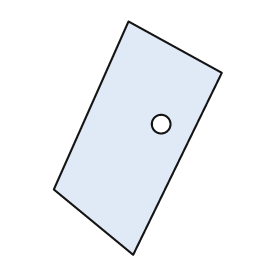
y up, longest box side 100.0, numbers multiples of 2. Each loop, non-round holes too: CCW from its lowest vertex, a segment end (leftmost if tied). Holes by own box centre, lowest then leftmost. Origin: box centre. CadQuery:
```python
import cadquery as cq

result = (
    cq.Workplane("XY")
    .moveTo(-2.0, -50.0)
    .lineTo(36.0, 28.0)
    .lineTo(-4.0, 50.0)
    .lineTo(-36.0, -22.0)
    .close()
    .moveTo(10.0, 6.0)
    .circle(4.0)
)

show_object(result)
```